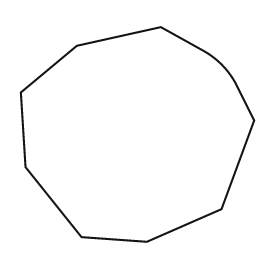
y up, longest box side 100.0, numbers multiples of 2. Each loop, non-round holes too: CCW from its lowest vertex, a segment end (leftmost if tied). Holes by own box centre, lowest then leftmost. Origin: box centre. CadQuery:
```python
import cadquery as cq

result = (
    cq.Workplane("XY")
    .moveTo(4.0, -46.0)
    .lineTo(36.0, -32.0)
    .lineTo(50.0, 6.0)
    .lineTo(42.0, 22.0)
    .threePointArc((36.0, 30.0), (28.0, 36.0))
    .lineTo(10.0, 46.0)
    .lineTo(-26.0, 38.0)
    .lineTo(-50.0, 18.0)
    .lineTo(-48.0, -14.0)
    .lineTo(-24.0, -44.0)
    .close()
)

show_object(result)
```